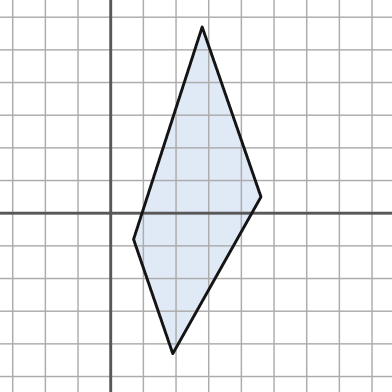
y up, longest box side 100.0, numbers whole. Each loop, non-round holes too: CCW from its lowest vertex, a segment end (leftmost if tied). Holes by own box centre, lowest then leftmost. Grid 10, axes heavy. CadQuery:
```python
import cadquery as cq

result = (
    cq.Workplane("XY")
    .moveTo(19.0, -43.0)
    .lineTo(46.0, 5.0)
    .lineTo(28.0, 57.0)
    .lineTo(7.0, -8.0)
    .close()
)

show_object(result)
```